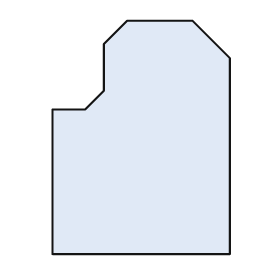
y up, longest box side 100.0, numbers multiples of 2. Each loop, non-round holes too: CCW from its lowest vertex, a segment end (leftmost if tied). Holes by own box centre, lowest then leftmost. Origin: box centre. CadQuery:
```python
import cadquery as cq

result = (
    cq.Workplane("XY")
    .moveTo(-38.0, -50.0)
    .lineTo(38.0, -50.0)
    .lineTo(38.0, 34.0)
    .lineTo(22.0, 50.0)
    .lineTo(-6.0, 50.0)
    .lineTo(-16.0, 40.0)
    .lineTo(-16.0, 20.0)
    .lineTo(-24.0, 12.0)
    .lineTo(-38.0, 12.0)
    .close()
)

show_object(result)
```